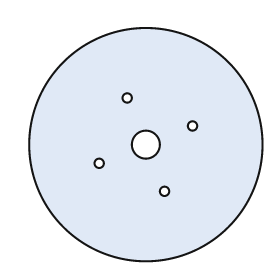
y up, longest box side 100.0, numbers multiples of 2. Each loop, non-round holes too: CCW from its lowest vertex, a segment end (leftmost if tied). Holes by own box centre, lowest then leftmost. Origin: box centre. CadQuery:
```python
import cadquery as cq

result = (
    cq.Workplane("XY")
    .moveTo(0.0, 0.0)
    .circle(50.0)
    .moveTo(8.0, -20.0)
    .circle(2.0)
    .moveTo(-20.0, -8.0)
    .circle(2.0)
    .moveTo(0.0, 0.0)
    .circle(6.0)
    .moveTo(20.0, 8.0)
    .circle(2.0)
    .moveTo(-8.0, 20.0)
    .circle(2.0)
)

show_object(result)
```